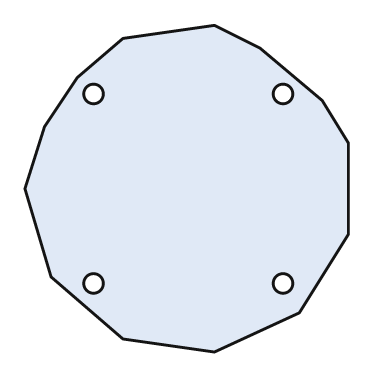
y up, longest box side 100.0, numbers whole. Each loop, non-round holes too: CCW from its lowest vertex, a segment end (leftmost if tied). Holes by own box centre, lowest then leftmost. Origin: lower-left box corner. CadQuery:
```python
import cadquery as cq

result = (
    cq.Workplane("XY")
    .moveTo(58.0, 0.0)
    .lineTo(84.0, 12.0)
    .lineTo(99.0, 36.0)
    .lineTo(99.0, 64.0)
    .lineTo(91.0, 77.0)
    .lineTo(72.0, 93.0)
    .lineTo(58.0, 100.0)
    .lineTo(30.0, 96.0)
    .lineTo(16.0, 84.0)
    .lineTo(6.0, 69.0)
    .lineTo(0.0, 50.0)
    .lineTo(8.0, 23.0)
    .lineTo(30.0, 4.0)
    .close()
    .moveTo(21.0, 21.0)
    .circle(3.0)
    .moveTo(79.0, 21.0)
    .circle(3.0)
    .moveTo(21.0, 79.0)
    .circle(3.0)
    .moveTo(79.0, 79.0)
    .circle(3.0)
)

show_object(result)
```